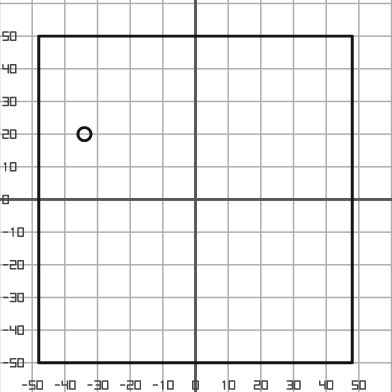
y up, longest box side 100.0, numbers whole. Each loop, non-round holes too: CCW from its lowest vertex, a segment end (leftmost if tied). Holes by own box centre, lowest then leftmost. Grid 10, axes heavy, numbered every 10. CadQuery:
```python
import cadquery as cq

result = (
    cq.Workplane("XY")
    .moveTo(-48.0, -50.0)
    .lineTo(48.0, -50.0)
    .lineTo(48.0, 50.0)
    .lineTo(-48.0, 50.0)
    .close()
    .moveTo(-34.0, 20.0)
    .circle(2.0)
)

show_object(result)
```